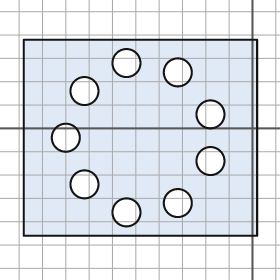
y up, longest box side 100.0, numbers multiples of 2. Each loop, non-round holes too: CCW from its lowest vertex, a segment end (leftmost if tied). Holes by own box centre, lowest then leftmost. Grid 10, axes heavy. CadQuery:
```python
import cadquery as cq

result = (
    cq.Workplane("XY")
    .moveTo(-98.0, -46.0)
    .lineTo(2.0, -46.0)
    .lineTo(2.0, 38.0)
    .lineTo(-98.0, 38.0)
    .close()
    .moveTo(-54.0, -36.0)
    .circle(6.0)
    .moveTo(-32.0, -32.0)
    .circle(6.0)
    .moveTo(-72.0, -24.0)
    .circle(6.0)
    .moveTo(-18.0, -14.0)
    .circle(6.0)
    .moveTo(-80.0, -4.0)
    .circle(6.0)
    .moveTo(-18.0, 6.0)
    .circle(6.0)
    .moveTo(-72.0, 16.0)
    .circle(6.0)
    .moveTo(-32.0, 24.0)
    .circle(6.0)
    .moveTo(-54.0, 28.0)
    .circle(6.0)
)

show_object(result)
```